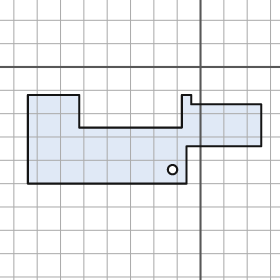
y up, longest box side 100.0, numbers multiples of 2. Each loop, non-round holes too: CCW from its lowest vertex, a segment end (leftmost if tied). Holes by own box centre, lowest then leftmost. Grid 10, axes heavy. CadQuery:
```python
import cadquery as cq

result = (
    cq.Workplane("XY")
    .moveTo(-74.0, -50.0)
    .lineTo(-6.0, -50.0)
    .lineTo(-6.0, -34.0)
    .lineTo(26.0, -34.0)
    .lineTo(26.0, -16.0)
    .lineTo(-4.0, -16.0)
    .lineTo(-4.0, -12.0)
    .lineTo(-8.0, -12.0)
    .lineTo(-8.0, -26.0)
    .lineTo(-52.0, -26.0)
    .lineTo(-52.0, -12.0)
    .lineTo(-74.0, -12.0)
    .close()
    .moveTo(-12.0, -44.0)
    .circle(2.0)
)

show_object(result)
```